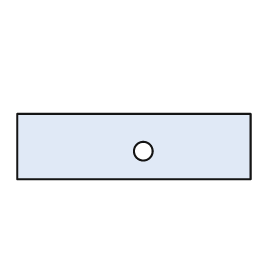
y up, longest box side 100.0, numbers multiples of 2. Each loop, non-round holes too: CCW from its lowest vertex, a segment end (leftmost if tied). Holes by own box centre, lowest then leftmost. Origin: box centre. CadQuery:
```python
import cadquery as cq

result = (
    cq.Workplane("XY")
    .moveTo(-50.0, -14.0)
    .lineTo(50.0, -14.0)
    .lineTo(50.0, 14.0)
    .lineTo(-50.0, 14.0)
    .close()
    .moveTo(4.0, -2.0)
    .circle(4.0)
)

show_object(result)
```